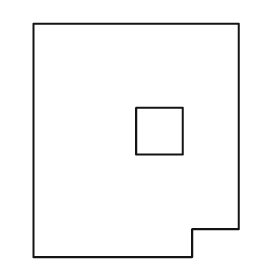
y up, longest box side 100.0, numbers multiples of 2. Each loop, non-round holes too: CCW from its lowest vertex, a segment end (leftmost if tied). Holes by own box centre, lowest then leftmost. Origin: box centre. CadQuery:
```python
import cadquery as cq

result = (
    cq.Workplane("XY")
    .moveTo(-44.0, -50.0)
    .lineTo(24.0, -50.0)
    .lineTo(24.0, -38.0)
    .lineTo(44.0, -38.0)
    .lineTo(44.0, 50.0)
    .lineTo(-44.0, 50.0)
    .close()
    .moveTo(0.0, -6.0)
    .lineTo(20.0, -6.0)
    .lineTo(20.0, 14.0)
    .lineTo(0.0, 14.0)
    .close()
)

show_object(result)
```